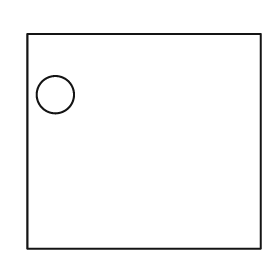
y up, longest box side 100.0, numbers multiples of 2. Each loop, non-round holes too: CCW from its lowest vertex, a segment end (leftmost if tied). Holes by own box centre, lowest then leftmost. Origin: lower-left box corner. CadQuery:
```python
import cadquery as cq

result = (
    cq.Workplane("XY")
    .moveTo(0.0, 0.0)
    .lineTo(100.0, 0.0)
    .lineTo(100.0, 92.0)
    .lineTo(0.0, 92.0)
    .close()
    .moveTo(12.0, 66.0)
    .circle(8.0)
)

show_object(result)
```